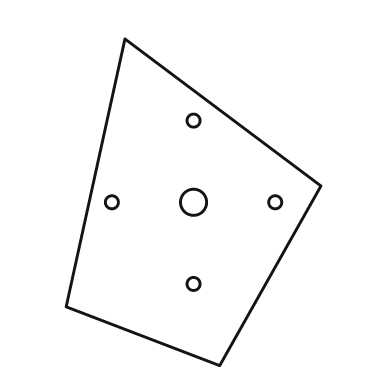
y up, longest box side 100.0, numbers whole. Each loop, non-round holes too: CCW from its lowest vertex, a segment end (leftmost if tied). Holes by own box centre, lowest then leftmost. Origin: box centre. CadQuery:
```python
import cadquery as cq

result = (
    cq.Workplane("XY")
    .moveTo(8.0, -50.0)
    .lineTo(39.0, 5.0)
    .lineTo(-21.0, 50.0)
    .lineTo(-39.0, -32.0)
    .close()
    .moveTo(0.0, -25.0)
    .circle(2.0)
    .moveTo(-25.0, 0.0)
    .circle(2.0)
    .moveTo(0.0, 0.0)
    .circle(4.0)
    .moveTo(25.0, 0.0)
    .circle(2.0)
    .moveTo(0.0, 25.0)
    .circle(2.0)
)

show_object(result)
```